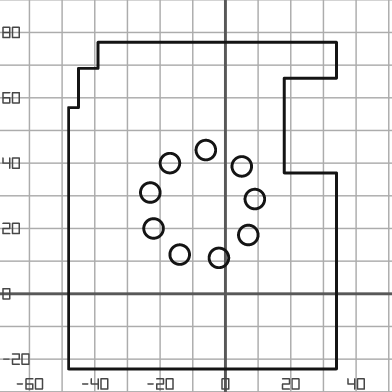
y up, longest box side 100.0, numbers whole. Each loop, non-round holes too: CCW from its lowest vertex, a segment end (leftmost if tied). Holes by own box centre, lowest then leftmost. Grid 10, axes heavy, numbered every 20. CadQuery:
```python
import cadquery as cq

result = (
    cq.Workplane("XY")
    .moveTo(-48.0, -23.0)
    .lineTo(34.0, -23.0)
    .lineTo(34.0, 37.0)
    .lineTo(18.0, 37.0)
    .lineTo(18.0, 66.0)
    .lineTo(34.0, 66.0)
    .lineTo(34.0, 77.0)
    .lineTo(-39.0, 77.0)
    .lineTo(-39.0, 69.0)
    .lineTo(-45.0, 69.0)
    .lineTo(-45.0, 57.0)
    .lineTo(-48.0, 57.0)
    .close()
    .moveTo(-2.0, 11.0)
    .circle(3.0)
    .moveTo(-14.0, 12.0)
    .circle(3.0)
    .moveTo(7.0, 18.0)
    .circle(3.0)
    .moveTo(-22.0, 20.0)
    .circle(3.0)
    .moveTo(9.0, 29.0)
    .circle(3.0)
    .moveTo(-23.0, 31.0)
    .circle(3.0)
    .moveTo(5.0, 39.0)
    .circle(3.0)
    .moveTo(-17.0, 40.0)
    .circle(3.0)
    .moveTo(-6.0, 44.0)
    .circle(3.0)
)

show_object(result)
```